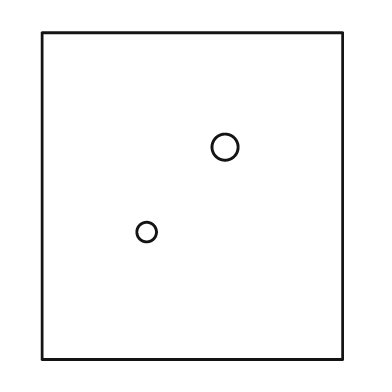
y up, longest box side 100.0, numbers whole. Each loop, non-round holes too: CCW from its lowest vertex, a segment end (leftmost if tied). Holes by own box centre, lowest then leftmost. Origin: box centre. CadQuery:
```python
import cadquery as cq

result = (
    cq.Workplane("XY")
    .moveTo(-46.0, -50.0)
    .lineTo(46.0, -50.0)
    .lineTo(46.0, 50.0)
    .lineTo(-46.0, 50.0)
    .close()
    .moveTo(-14.0, -11.0)
    .circle(3.0)
    .moveTo(10.0, 15.0)
    .circle(4.0)
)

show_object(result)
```